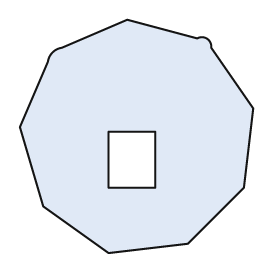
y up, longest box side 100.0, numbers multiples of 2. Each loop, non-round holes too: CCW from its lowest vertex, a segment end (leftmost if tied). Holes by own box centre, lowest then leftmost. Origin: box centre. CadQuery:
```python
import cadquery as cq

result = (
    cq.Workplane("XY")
    .moveTo(-12.0, -50.0)
    .lineTo(22.0, -46.0)
    .lineTo(46.0, -22.0)
    .lineTo(50.0, 12.0)
    .lineTo(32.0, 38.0)
    .threePointArc((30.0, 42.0), (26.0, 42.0))
    .lineTo(-4.0, 50.0)
    .lineTo(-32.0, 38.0)
    .threePointArc((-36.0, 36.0), (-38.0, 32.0))
    .lineTo(-50.0, 4.0)
    .lineTo(-40.0, -30.0)
    .close()
    .moveTo(-12.0, -22.0)
    .lineTo(8.0, -22.0)
    .lineTo(8.0, 2.0)
    .lineTo(-12.0, 2.0)
    .close()
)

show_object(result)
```